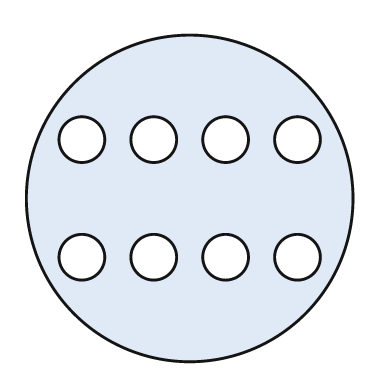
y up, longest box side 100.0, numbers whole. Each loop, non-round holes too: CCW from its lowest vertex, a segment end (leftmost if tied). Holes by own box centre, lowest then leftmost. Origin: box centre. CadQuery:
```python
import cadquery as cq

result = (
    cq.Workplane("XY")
    .moveTo(0.0, 0.0)
    .circle(50.0)
    .moveTo(-33.0, -18.0)
    .circle(7.0)
    .moveTo(-11.0, -18.0)
    .circle(7.0)
    .moveTo(11.0, -18.0)
    .circle(7.0)
    .moveTo(33.0, -18.0)
    .circle(7.0)
    .moveTo(-33.0, 18.0)
    .circle(7.0)
    .moveTo(-11.0, 18.0)
    .circle(7.0)
    .moveTo(11.0, 18.0)
    .circle(7.0)
    .moveTo(33.0, 18.0)
    .circle(7.0)
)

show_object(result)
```